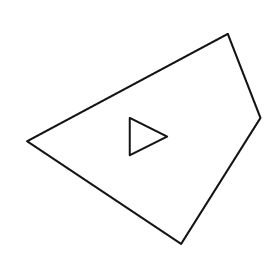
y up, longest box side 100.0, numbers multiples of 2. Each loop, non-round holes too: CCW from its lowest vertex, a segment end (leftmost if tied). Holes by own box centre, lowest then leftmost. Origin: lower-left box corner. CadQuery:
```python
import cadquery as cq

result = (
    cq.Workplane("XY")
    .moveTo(66.0, 0.0)
    .lineTo(100.0, 54.0)
    .lineTo(86.0, 90.0)
    .lineTo(0.0, 44.0)
    .close()
    .moveTo(44.0, 38.0)
    .lineTo(60.0, 46.0)
    .lineTo(44.0, 54.0)
    .close()
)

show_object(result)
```